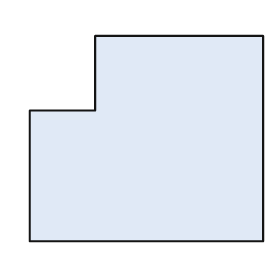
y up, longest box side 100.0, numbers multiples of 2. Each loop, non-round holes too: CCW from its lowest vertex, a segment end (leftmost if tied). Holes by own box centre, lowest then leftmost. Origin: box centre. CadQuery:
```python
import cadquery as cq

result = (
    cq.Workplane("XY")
    .moveTo(-50.0, -44.0)
    .lineTo(50.0, -44.0)
    .lineTo(50.0, 44.0)
    .lineTo(-22.0, 44.0)
    .lineTo(-22.0, 12.0)
    .lineTo(-50.0, 12.0)
    .close()
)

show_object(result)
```